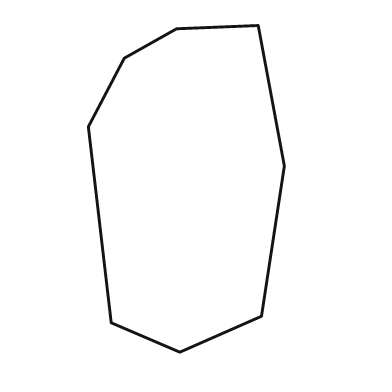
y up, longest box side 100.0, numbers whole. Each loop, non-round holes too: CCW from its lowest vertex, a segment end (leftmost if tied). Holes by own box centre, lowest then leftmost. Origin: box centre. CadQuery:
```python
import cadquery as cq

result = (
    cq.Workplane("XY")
    .moveTo(-2.0, -50.0)
    .lineTo(23.0, -39.0)
    .lineTo(30.0, 7.0)
    .lineTo(22.0, 50.0)
    .lineTo(-3.0, 49.0)
    .lineTo(-19.0, 40.0)
    .lineTo(-30.0, 19.0)
    .lineTo(-23.0, -41.0)
    .close()
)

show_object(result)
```